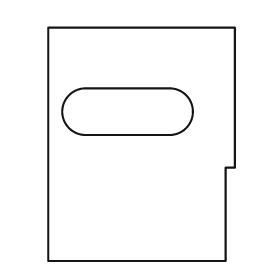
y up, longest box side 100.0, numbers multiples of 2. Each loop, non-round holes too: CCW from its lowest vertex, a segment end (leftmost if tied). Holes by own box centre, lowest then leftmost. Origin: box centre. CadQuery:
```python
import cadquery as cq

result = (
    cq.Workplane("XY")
    .moveTo(-40.0, -50.0)
    .lineTo(36.0, -50.0)
    .lineTo(36.0, -10.0)
    .lineTo(40.0, -10.0)
    .lineTo(40.0, 50.0)
    .lineTo(-40.0, 50.0)
    .close()
    .moveTo(-24.0, 4.0)
    .lineTo(12.0, 4.0)
    .threePointArc((22.0, 14.0), (12.0, 24.0))
    .lineTo(-24.0, 24.0)
    .threePointArc((-34.0, 14.0), (-24.0, 4.0))
    .close()
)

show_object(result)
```